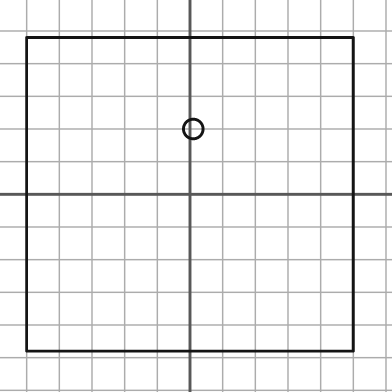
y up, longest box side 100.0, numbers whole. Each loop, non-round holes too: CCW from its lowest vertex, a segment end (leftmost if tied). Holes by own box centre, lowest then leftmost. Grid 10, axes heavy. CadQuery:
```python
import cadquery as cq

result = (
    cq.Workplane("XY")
    .moveTo(-50.0, -48.0)
    .lineTo(50.0, -48.0)
    .lineTo(50.0, 48.0)
    .lineTo(-50.0, 48.0)
    .close()
    .moveTo(1.0, 20.0)
    .circle(3.0)
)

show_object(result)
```